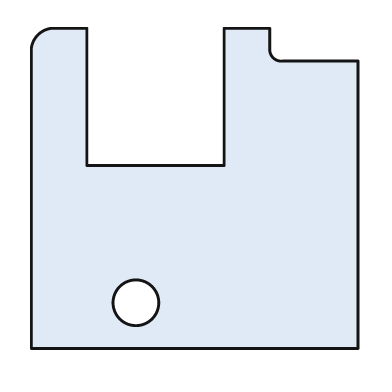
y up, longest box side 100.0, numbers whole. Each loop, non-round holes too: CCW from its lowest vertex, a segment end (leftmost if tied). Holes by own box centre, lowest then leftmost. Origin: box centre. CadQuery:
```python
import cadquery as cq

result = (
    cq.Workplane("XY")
    .moveTo(-50.0, -49.0)
    .lineTo(50.0, -49.0)
    .lineTo(50.0, 39.0)
    .lineTo(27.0, 39.0)
    .threePointArc((24.0, 40.0), (23.0, 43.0))
    .lineTo(23.0, 49.0)
    .lineTo(9.0, 49.0)
    .lineTo(9.0, 7.0)
    .lineTo(-33.0, 7.0)
    .lineTo(-33.0, 49.0)
    .lineTo(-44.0, 49.0)
    .threePointArc((-48.0, 47.0), (-50.0, 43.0))
    .close()
    .moveTo(-18.0, -35.0)
    .circle(7.0)
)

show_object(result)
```